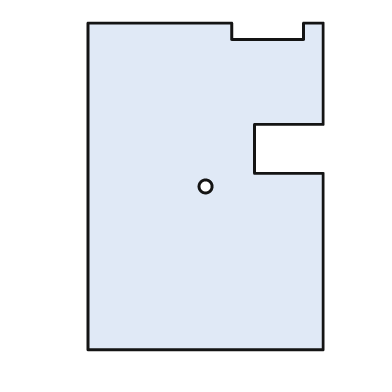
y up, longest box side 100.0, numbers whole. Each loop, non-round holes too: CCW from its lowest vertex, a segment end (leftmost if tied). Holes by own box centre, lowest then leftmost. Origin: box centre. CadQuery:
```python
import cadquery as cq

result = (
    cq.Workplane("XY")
    .moveTo(-36.0, -50.0)
    .lineTo(36.0, -50.0)
    .lineTo(36.0, 4.0)
    .lineTo(15.0, 4.0)
    .lineTo(15.0, 19.0)
    .lineTo(36.0, 19.0)
    .lineTo(36.0, 50.0)
    .lineTo(30.0, 50.0)
    .lineTo(30.0, 45.0)
    .lineTo(8.0, 45.0)
    .lineTo(8.0, 50.0)
    .lineTo(-36.0, 50.0)
    .close()
    .moveTo(0.0, 0.0)
    .circle(2.0)
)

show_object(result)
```